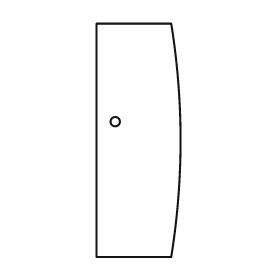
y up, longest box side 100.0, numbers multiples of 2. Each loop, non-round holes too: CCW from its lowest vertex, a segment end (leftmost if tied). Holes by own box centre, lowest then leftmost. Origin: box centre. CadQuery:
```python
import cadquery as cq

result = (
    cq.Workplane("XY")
    .moveTo(-18.0, -50.0)
    .lineTo(14.0, -50.0)
    .threePointArc((18.0, 0.0), (14.0, 50.0))
    .lineTo(-18.0, 50.0)
    .close()
    .moveTo(-10.0, 8.0)
    .circle(2.0)
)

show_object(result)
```